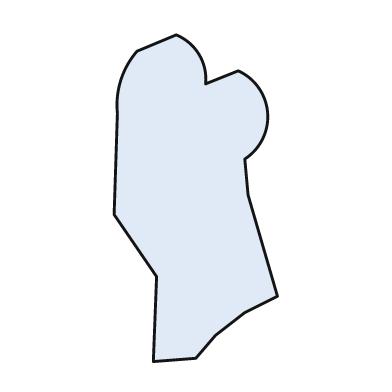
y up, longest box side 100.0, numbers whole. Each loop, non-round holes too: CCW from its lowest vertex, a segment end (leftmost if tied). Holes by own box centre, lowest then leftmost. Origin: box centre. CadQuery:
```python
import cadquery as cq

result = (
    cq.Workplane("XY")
    .moveTo(-13.0, -50.0)
    .lineTo(0.0, -49.0)
    .lineTo(6.0, -42.0)
    .lineTo(15.0, -35.0)
    .lineTo(25.0, -30.0)
    .lineTo(16.0, 1.0)
    .lineTo(15.0, 12.0)
    .threePointArc((22.0, 26.0), (13.0, 39.0))
    .lineTo(3.0, 35.0)
    .threePointArc((1.0, 44.0), (-6.0, 50.0))
    .lineTo(-18.0, 45.0)
    .threePointArc((-23.0, 36.0), (-24.0, 26.0))
    .lineTo(-25.0, -5.0)
    .lineTo(-12.0, -24.0)
    .close()
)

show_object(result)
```